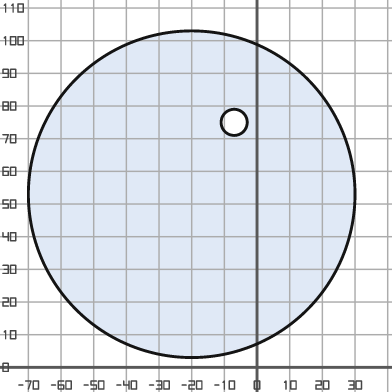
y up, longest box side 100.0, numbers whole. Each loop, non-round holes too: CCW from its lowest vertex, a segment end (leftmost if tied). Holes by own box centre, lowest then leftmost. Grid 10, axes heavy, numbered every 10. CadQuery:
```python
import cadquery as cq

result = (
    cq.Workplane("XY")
    .moveTo(-20.0, 53.0)
    .circle(50.0)
    .moveTo(-7.0, 75.0)
    .circle(4.0)
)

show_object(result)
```